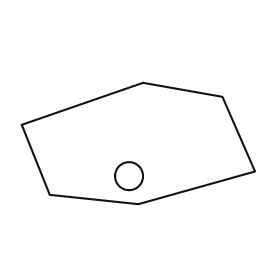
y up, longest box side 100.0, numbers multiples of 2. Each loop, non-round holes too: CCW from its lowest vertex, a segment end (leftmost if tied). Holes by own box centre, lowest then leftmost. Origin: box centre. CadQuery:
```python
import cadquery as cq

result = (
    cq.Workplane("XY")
    .moveTo(0.0, -26.0)
    .lineTo(50.0, -12.0)
    .lineTo(36.0, 20.0)
    .lineTo(2.0, 26.0)
    .lineTo(-50.0, 8.0)
    .lineTo(-38.0, -22.0)
    .close()
    .moveTo(-4.0, -14.0)
    .circle(6.0)
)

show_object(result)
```